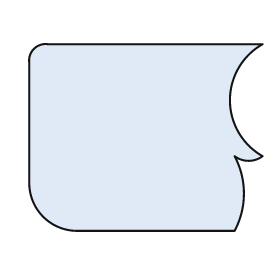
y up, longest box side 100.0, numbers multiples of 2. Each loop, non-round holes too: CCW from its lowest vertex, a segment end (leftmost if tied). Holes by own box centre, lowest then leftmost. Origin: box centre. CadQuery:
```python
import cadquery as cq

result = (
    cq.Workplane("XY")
    .moveTo(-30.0, -40.0)
    .lineTo(38.0, -40.0)
    .threePointArc((42.0, -24.0), (38.0, -8.0))
    .threePointArc((44.0, -10.0), (50.0, -8.0))
    .threePointArc((36.0, 16.0), (50.0, 40.0))
    .lineTo(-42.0, 40.0)
    .threePointArc((-48.0, 38.0), (-50.0, 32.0))
    .lineTo(-50.0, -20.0)
    .threePointArc((-44.0, -34.0), (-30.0, -40.0))
    .close()
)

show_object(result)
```